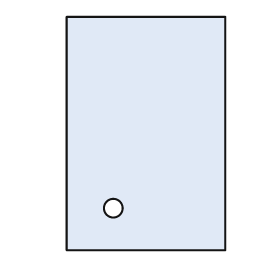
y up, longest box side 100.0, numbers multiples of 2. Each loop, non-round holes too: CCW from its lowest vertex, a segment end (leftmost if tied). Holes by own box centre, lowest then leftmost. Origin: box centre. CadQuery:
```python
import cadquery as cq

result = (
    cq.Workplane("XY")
    .moveTo(-34.0, -50.0)
    .lineTo(34.0, -50.0)
    .lineTo(34.0, 50.0)
    .lineTo(-34.0, 50.0)
    .close()
    .moveTo(-14.0, -32.0)
    .circle(4.0)
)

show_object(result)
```